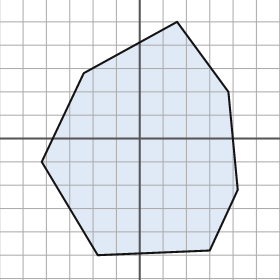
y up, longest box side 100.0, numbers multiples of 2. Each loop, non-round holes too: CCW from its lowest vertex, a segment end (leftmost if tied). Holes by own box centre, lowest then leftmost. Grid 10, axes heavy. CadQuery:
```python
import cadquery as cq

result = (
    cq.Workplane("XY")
    .moveTo(-18.0, -50.0)
    .lineTo(30.0, -48.0)
    .lineTo(42.0, -22.0)
    .lineTo(38.0, 20.0)
    .lineTo(16.0, 50.0)
    .lineTo(-24.0, 28.0)
    .lineTo(-42.0, -10.0)
    .close()
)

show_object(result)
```